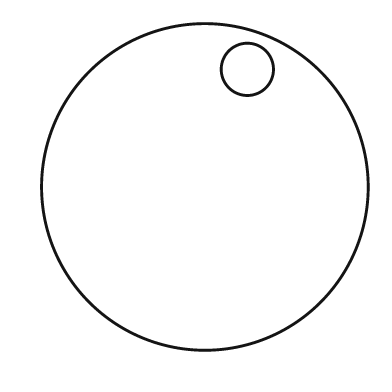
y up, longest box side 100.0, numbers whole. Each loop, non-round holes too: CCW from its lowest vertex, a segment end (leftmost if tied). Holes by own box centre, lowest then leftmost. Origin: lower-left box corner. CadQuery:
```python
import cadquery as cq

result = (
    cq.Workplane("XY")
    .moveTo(50.0, 50.0)
    .circle(50.0)
    .moveTo(63.0, 86.0)
    .circle(8.0)
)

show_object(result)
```